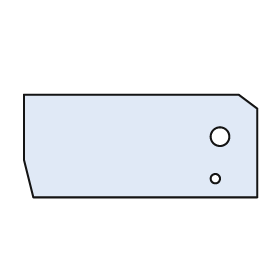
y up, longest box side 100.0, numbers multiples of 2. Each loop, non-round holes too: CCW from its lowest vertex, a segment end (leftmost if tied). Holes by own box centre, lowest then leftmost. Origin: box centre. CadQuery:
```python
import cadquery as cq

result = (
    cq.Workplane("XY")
    .moveTo(-46.0, -22.0)
    .lineTo(50.0, -22.0)
    .lineTo(50.0, 16.0)
    .lineTo(42.0, 22.0)
    .lineTo(-50.0, 22.0)
    .lineTo(-50.0, -6.0)
    .close()
    .moveTo(32.0, -14.0)
    .circle(2.0)
    .moveTo(34.0, 4.0)
    .circle(4.0)
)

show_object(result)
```